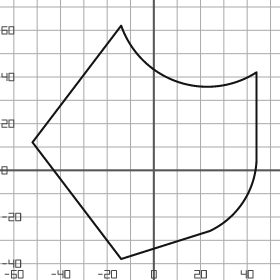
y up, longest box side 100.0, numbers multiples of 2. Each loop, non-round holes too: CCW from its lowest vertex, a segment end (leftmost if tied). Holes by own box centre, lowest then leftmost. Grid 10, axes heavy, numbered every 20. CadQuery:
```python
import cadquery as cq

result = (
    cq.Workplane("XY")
    .moveTo(-14.0, -38.0)
    .lineTo(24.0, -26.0)
    .threePointArc((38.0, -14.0), (44.0, 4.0))
    .lineTo(44.0, 42.0)
    .threePointArc((10.0, 38.0), (-14.0, 62.0))
    .lineTo(-52.0, 12.0)
    .close()
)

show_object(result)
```